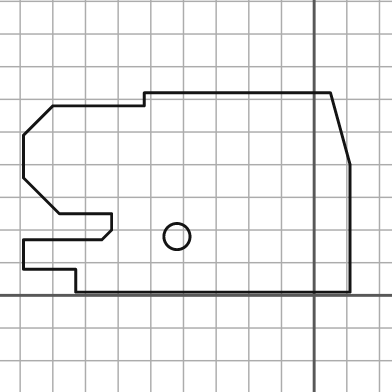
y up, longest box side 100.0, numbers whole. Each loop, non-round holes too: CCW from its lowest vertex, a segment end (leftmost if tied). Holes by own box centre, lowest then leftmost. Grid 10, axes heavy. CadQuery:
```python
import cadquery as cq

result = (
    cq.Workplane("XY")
    .moveTo(-73.0, 1.0)
    .lineTo(11.0, 1.0)
    .lineTo(11.0, 40.0)
    .lineTo(5.0, 62.0)
    .lineTo(-52.0, 62.0)
    .lineTo(-52.0, 58.0)
    .lineTo(-80.0, 58.0)
    .lineTo(-89.0, 49.0)
    .lineTo(-89.0, 36.0)
    .lineTo(-78.0, 25.0)
    .lineTo(-62.0, 25.0)
    .lineTo(-62.0, 20.0)
    .lineTo(-65.0, 17.0)
    .lineTo(-89.0, 17.0)
    .lineTo(-89.0, 8.0)
    .lineTo(-73.0, 8.0)
    .close()
    .moveTo(-42.0, 18.0)
    .circle(4.0)
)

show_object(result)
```